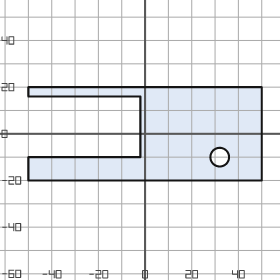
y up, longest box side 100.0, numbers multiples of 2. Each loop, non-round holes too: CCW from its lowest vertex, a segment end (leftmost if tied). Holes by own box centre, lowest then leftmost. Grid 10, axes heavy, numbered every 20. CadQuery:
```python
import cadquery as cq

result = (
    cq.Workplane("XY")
    .moveTo(-50.0, -20.0)
    .lineTo(50.0, -20.0)
    .lineTo(50.0, 20.0)
    .lineTo(-50.0, 20.0)
    .lineTo(-50.0, 16.0)
    .lineTo(-2.0, 16.0)
    .lineTo(-2.0, -10.0)
    .lineTo(-50.0, -10.0)
    .close()
    .moveTo(32.0, -10.0)
    .circle(4.0)
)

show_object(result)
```